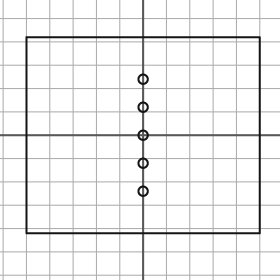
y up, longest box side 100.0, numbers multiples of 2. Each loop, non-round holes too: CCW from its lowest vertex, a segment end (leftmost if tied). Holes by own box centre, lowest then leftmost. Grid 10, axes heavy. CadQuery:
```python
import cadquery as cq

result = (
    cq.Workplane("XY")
    .moveTo(-50.0, -42.0)
    .lineTo(50.0, -42.0)
    .lineTo(50.0, 42.0)
    .lineTo(-50.0, 42.0)
    .close()
    .moveTo(0.0, -24.0)
    .circle(2.0)
    .moveTo(0.0, -12.0)
    .circle(2.0)
    .moveTo(0.0, 0.0)
    .circle(2.0)
    .moveTo(0.0, 12.0)
    .circle(2.0)
    .moveTo(0.0, 24.0)
    .circle(2.0)
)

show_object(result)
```